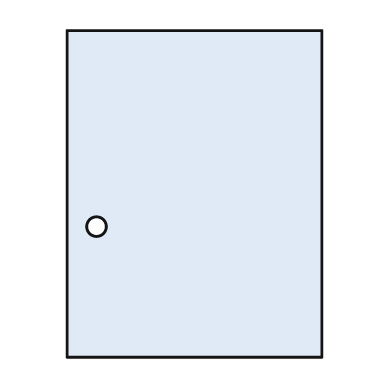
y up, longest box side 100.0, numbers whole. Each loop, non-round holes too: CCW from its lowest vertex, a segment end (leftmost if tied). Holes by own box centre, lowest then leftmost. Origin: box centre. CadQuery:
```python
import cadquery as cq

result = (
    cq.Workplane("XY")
    .moveTo(-39.0, -50.0)
    .lineTo(39.0, -50.0)
    .lineTo(39.0, 50.0)
    .lineTo(-39.0, 50.0)
    .close()
    .moveTo(-30.0, -10.0)
    .circle(3.0)
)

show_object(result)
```